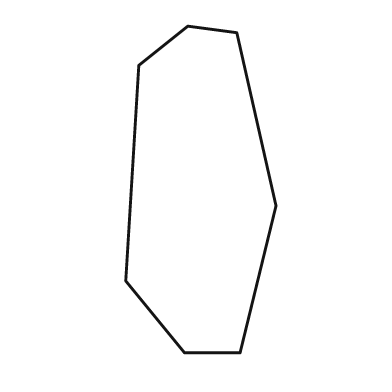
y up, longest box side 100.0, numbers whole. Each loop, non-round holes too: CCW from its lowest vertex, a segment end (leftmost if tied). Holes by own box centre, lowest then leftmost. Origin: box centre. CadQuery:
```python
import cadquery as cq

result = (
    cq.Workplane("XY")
    .moveTo(-5.0, -50.0)
    .lineTo(12.0, -50.0)
    .lineTo(23.0, -5.0)
    .lineTo(11.0, 48.0)
    .lineTo(-4.0, 50.0)
    .lineTo(-19.0, 38.0)
    .lineTo(-23.0, -28.0)
    .close()
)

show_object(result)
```